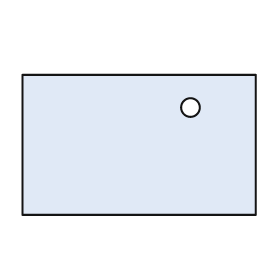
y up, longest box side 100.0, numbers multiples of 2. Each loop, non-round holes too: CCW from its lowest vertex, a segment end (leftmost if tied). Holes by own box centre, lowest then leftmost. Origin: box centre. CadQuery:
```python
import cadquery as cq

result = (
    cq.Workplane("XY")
    .moveTo(-50.0, -30.0)
    .lineTo(50.0, -30.0)
    .lineTo(50.0, 30.0)
    .lineTo(-50.0, 30.0)
    .close()
    .moveTo(22.0, 16.0)
    .circle(4.0)
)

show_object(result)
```